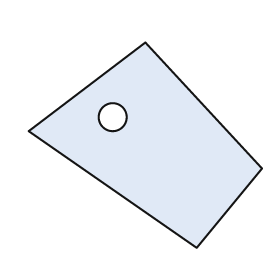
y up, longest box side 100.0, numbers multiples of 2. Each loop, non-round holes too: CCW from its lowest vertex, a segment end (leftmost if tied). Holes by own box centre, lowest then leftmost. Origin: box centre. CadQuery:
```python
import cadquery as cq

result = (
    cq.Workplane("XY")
    .moveTo(22.0, -44.0)
    .lineTo(50.0, -10.0)
    .lineTo(0.0, 44.0)
    .lineTo(-50.0, 6.0)
    .close()
    .moveTo(-14.0, 12.0)
    .circle(6.0)
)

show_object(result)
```